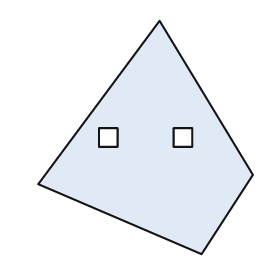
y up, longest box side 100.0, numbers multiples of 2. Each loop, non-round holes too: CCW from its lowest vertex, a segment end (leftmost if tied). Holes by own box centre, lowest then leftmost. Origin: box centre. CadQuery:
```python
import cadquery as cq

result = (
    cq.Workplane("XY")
    .moveTo(24.0, -50.0)
    .lineTo(46.0, -16.0)
    .lineTo(6.0, 50.0)
    .lineTo(-46.0, -20.0)
    .close()
    .moveTo(-20.0, -4.0)
    .lineTo(-12.0, -4.0)
    .lineTo(-12.0, 4.0)
    .lineTo(-20.0, 4.0)
    .close()
    .moveTo(12.0, -4.0)
    .lineTo(20.0, -4.0)
    .lineTo(20.0, 4.0)
    .lineTo(12.0, 4.0)
    .close()
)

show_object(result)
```